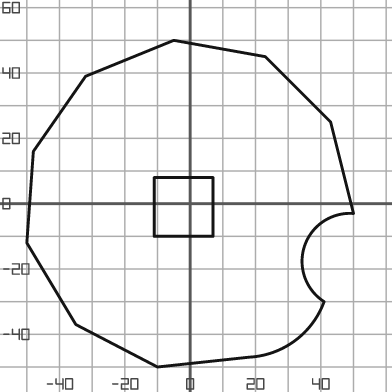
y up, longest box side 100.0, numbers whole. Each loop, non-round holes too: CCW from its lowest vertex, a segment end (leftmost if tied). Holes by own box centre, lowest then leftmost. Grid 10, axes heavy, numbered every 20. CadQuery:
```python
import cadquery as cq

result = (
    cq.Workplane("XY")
    .moveTo(-10.0, -50.0)
    .lineTo(18.0, -47.0)
    .threePointArc((32.0, -42.0), (41.0, -30.0))
    .threePointArc((35.0, -13.0), (50.0, -3.0))
    .lineTo(43.0, 25.0)
    .lineTo(23.0, 45.0)
    .lineTo(-5.0, 50.0)
    .lineTo(-32.0, 39.0)
    .lineTo(-48.0, 16.0)
    .lineTo(-50.0, -12.0)
    .lineTo(-35.0, -37.0)
    .close()
    .moveTo(-11.0, -10.0)
    .lineTo(7.0, -10.0)
    .lineTo(7.0, 8.0)
    .lineTo(-11.0, 8.0)
    .close()
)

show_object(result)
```